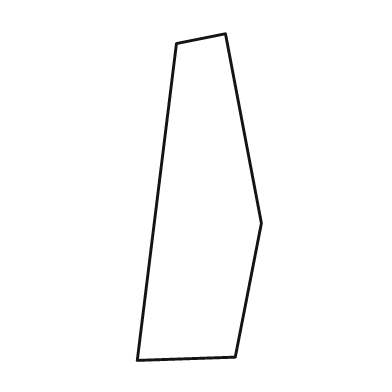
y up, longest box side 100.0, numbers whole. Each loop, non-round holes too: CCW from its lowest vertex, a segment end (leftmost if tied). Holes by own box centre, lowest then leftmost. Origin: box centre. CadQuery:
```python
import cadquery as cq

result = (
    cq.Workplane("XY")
    .moveTo(-19.0, -50.0)
    .lineTo(11.0, -49.0)
    .lineTo(19.0, -8.0)
    .lineTo(8.0, 50.0)
    .lineTo(-7.0, 47.0)
    .close()
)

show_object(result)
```